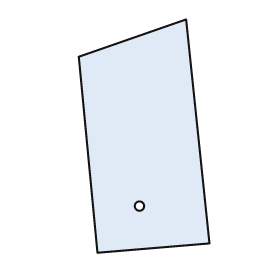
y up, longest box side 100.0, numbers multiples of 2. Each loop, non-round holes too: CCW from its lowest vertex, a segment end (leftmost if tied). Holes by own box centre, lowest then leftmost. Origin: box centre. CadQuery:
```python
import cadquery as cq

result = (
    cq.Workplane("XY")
    .moveTo(-20.0, -50.0)
    .lineTo(28.0, -46.0)
    .lineTo(18.0, 50.0)
    .lineTo(-28.0, 34.0)
    .close()
    .moveTo(-2.0, -30.0)
    .circle(2.0)
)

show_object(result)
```